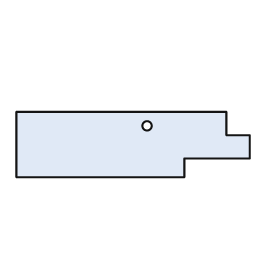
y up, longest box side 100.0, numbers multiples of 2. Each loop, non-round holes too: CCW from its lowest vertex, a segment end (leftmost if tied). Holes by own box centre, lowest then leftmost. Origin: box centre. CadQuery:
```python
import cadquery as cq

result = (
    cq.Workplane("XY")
    .moveTo(-50.0, -14.0)
    .lineTo(22.0, -14.0)
    .lineTo(22.0, -6.0)
    .lineTo(50.0, -6.0)
    .lineTo(50.0, 4.0)
    .lineTo(40.0, 4.0)
    .lineTo(40.0, 14.0)
    .lineTo(-50.0, 14.0)
    .close()
    .moveTo(6.0, 8.0)
    .circle(2.0)
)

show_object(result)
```